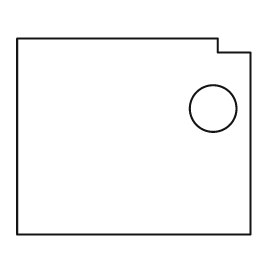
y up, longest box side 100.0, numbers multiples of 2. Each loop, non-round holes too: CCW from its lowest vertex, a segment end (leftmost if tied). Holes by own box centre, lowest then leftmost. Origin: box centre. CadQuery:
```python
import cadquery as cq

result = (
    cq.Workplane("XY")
    .moveTo(-50.0, -42.0)
    .lineTo(50.0, -42.0)
    .lineTo(50.0, 36.0)
    .lineTo(36.0, 36.0)
    .lineTo(36.0, 42.0)
    .lineTo(-50.0, 42.0)
    .close()
    .moveTo(34.0, 12.0)
    .circle(10.0)
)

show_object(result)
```